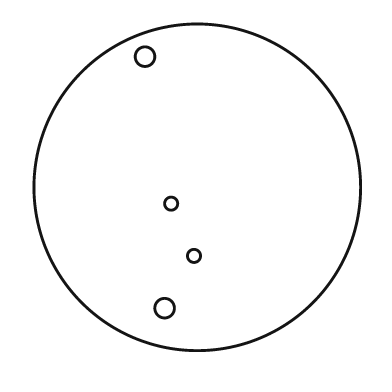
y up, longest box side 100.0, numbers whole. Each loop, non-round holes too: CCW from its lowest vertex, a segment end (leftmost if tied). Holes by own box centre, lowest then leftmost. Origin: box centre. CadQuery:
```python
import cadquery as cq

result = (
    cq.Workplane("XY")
    .moveTo(0.0, 0.0)
    .circle(50.0)
    .moveTo(-10.0, -37.0)
    .circle(3.0)
    .moveTo(-1.0, -21.0)
    .circle(2.0)
    .moveTo(-8.0, -5.0)
    .circle(2.0)
    .moveTo(-16.0, 40.0)
    .circle(3.0)
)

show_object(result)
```